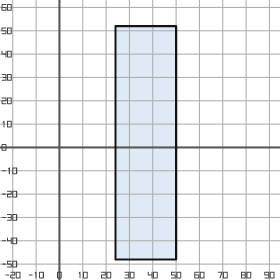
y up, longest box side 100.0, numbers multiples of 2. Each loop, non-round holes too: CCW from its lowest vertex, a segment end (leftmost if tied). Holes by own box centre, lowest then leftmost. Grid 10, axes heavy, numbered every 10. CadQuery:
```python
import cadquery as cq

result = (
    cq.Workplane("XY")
    .moveTo(24.0, -48.0)
    .lineTo(50.0, -48.0)
    .lineTo(50.0, 52.0)
    .lineTo(24.0, 52.0)
    .close()
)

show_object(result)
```